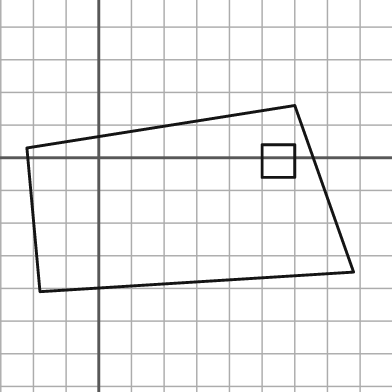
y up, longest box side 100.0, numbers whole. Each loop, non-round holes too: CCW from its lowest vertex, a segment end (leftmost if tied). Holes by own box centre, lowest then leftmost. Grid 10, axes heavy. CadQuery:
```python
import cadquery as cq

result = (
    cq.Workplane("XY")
    .moveTo(-18.0, -41.0)
    .lineTo(78.0, -35.0)
    .lineTo(60.0, 16.0)
    .lineTo(-22.0, 3.0)
    .close()
    .moveTo(50.0, -6.0)
    .lineTo(60.0, -6.0)
    .lineTo(60.0, 4.0)
    .lineTo(50.0, 4.0)
    .close()
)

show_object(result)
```